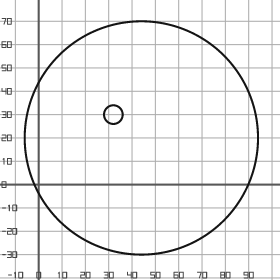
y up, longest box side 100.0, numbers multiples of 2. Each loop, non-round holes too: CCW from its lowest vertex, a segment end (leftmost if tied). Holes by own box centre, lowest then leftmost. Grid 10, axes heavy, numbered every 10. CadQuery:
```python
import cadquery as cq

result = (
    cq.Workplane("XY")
    .moveTo(44.0, 20.0)
    .circle(50.0)
    .moveTo(32.0, 30.0)
    .circle(4.0)
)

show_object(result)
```